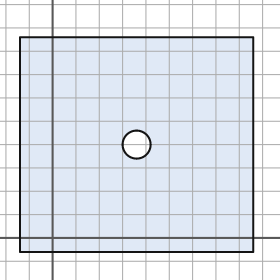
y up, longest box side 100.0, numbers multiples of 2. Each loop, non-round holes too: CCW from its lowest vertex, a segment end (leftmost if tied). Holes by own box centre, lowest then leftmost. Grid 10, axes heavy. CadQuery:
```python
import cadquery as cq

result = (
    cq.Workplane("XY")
    .moveTo(-14.0, -6.0)
    .lineTo(86.0, -6.0)
    .lineTo(86.0, 86.0)
    .lineTo(-14.0, 86.0)
    .close()
    .moveTo(36.0, 40.0)
    .circle(6.0)
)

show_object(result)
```